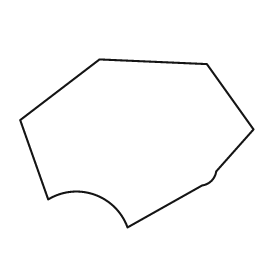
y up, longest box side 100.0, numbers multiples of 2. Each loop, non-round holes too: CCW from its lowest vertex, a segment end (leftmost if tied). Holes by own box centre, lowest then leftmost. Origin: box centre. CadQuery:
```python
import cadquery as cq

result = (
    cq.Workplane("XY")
    .moveTo(-4.0, -36.0)
    .lineTo(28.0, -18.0)
    .threePointArc((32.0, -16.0), (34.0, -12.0))
    .lineTo(50.0, 6.0)
    .lineTo(30.0, 34.0)
    .lineTo(-16.0, 36.0)
    .lineTo(-50.0, 10.0)
    .lineTo(-38.0, -24.0)
    .threePointArc((-18.0, -22.0), (-4.0, -36.0))
    .close()
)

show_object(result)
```